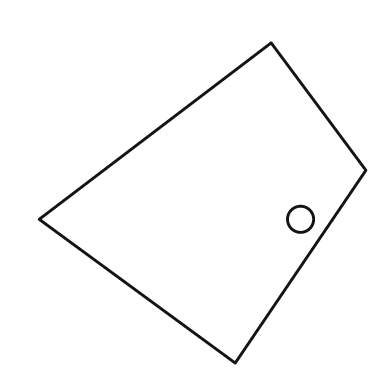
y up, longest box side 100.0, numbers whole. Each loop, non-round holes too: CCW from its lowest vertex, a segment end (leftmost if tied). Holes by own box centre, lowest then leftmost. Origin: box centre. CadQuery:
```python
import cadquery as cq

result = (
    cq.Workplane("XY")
    .moveTo(10.0, -49.0)
    .lineTo(50.0, 10.0)
    .lineTo(21.0, 49.0)
    .lineTo(-50.0, -5.0)
    .close()
    .moveTo(30.0, -5.0)
    .circle(4.0)
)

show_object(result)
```